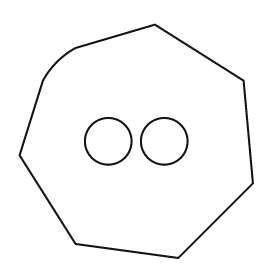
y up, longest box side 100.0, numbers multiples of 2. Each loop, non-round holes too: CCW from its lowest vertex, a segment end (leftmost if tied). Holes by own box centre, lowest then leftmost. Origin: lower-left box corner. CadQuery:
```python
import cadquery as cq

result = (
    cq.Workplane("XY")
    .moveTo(68.0, 0.0)
    .lineTo(100.0, 32.0)
    .lineTo(96.0, 76.0)
    .lineTo(58.0, 100.0)
    .lineTo(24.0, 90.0)
    .threePointArc((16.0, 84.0), (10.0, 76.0))
    .lineTo(0.0, 44.0)
    .lineTo(24.0, 6.0)
    .close()
    .moveTo(38.0, 50.0)
    .circle(10.0)
    .moveTo(62.0, 50.0)
    .circle(10.0)
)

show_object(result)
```